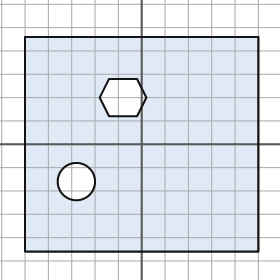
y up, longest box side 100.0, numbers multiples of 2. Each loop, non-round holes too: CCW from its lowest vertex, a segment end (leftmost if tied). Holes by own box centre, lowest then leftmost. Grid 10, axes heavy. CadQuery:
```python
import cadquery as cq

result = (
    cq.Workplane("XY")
    .moveTo(-50.0, -46.0)
    .lineTo(50.0, -46.0)
    .lineTo(50.0, 46.0)
    .lineTo(-50.0, 46.0)
    .close()
    .moveTo(-28.0, -16.0)
    .circle(8.0)
    .moveTo(-14.0, 12.0)
    .lineTo(-2.0, 12.0)
    .lineTo(2.0, 20.0)
    .lineTo(-2.0, 28.0)
    .lineTo(-14.0, 28.0)
    .lineTo(-18.0, 20.0)
    .close()
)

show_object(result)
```